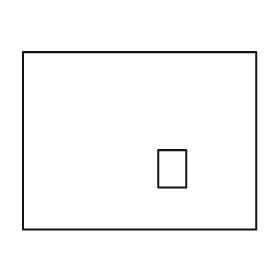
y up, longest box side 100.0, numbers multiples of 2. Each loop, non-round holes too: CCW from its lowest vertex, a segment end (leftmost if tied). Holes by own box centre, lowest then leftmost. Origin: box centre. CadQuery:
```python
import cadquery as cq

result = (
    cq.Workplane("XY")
    .moveTo(-50.0, -38.0)
    .lineTo(50.0, -38.0)
    .lineTo(50.0, 38.0)
    .lineTo(-50.0, 38.0)
    .close()
    .moveTo(8.0, -20.0)
    .lineTo(20.0, -20.0)
    .lineTo(20.0, -4.0)
    .lineTo(8.0, -4.0)
    .close()
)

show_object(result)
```